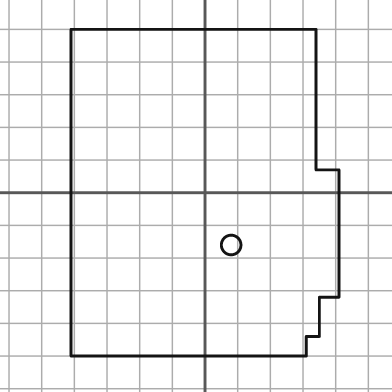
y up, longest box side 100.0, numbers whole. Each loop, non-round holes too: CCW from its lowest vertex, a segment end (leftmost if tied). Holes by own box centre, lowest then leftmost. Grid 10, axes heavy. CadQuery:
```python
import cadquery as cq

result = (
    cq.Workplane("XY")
    .moveTo(-41.0, -50.0)
    .lineTo(31.0, -50.0)
    .lineTo(31.0, -44.0)
    .lineTo(35.0, -44.0)
    .lineTo(35.0, -32.0)
    .lineTo(41.0, -32.0)
    .lineTo(41.0, 7.0)
    .lineTo(34.0, 7.0)
    .lineTo(34.0, 50.0)
    .lineTo(-41.0, 50.0)
    .close()
    .moveTo(8.0, -16.0)
    .circle(3.0)
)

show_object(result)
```